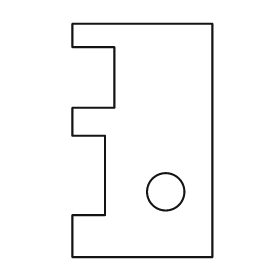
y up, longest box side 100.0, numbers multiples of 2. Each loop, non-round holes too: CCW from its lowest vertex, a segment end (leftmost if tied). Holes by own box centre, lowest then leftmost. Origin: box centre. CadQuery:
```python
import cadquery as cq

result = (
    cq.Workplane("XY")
    .moveTo(-30.0, -50.0)
    .lineTo(30.0, -50.0)
    .lineTo(30.0, 50.0)
    .lineTo(-30.0, 50.0)
    .lineTo(-30.0, 40.0)
    .lineTo(-12.0, 40.0)
    .lineTo(-12.0, 14.0)
    .lineTo(-30.0, 14.0)
    .lineTo(-30.0, 2.0)
    .lineTo(-16.0, 2.0)
    .lineTo(-16.0, -32.0)
    .lineTo(-30.0, -32.0)
    .close()
    .moveTo(10.0, -22.0)
    .circle(8.0)
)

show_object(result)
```